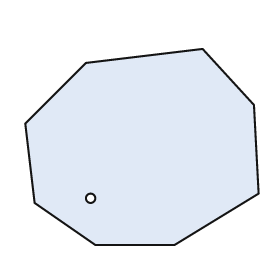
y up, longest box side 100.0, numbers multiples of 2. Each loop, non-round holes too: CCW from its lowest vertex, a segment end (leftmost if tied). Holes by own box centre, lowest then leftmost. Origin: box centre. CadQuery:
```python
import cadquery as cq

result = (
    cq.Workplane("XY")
    .moveTo(-20.0, -42.0)
    .lineTo(14.0, -42.0)
    .lineTo(50.0, -20.0)
    .lineTo(48.0, 18.0)
    .lineTo(26.0, 42.0)
    .lineTo(-24.0, 36.0)
    .lineTo(-50.0, 10.0)
    .lineTo(-46.0, -24.0)
    .close()
    .moveTo(-22.0, -22.0)
    .circle(2.0)
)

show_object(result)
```